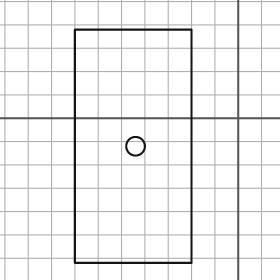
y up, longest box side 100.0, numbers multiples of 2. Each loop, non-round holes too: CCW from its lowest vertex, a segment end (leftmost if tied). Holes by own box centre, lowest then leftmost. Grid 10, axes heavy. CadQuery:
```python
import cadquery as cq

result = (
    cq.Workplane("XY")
    .moveTo(-70.0, -62.0)
    .lineTo(-20.0, -62.0)
    .lineTo(-20.0, 38.0)
    .lineTo(-70.0, 38.0)
    .close()
    .moveTo(-44.0, -12.0)
    .circle(4.0)
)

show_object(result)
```